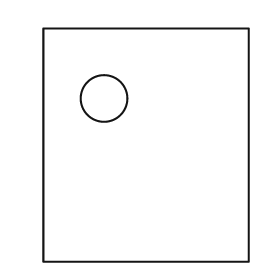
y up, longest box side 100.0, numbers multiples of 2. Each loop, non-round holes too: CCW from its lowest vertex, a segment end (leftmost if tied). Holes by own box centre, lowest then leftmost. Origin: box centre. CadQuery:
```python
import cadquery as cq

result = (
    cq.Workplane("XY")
    .moveTo(-44.0, -50.0)
    .lineTo(44.0, -50.0)
    .lineTo(44.0, 50.0)
    .lineTo(-44.0, 50.0)
    .close()
    .moveTo(-18.0, 20.0)
    .circle(10.0)
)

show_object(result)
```